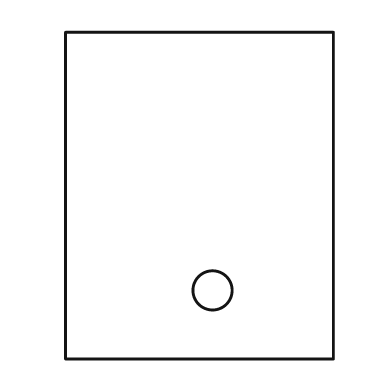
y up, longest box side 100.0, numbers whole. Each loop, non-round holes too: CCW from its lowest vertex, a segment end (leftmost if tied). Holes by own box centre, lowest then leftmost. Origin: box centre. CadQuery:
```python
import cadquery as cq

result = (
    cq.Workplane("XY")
    .moveTo(-41.0, -50.0)
    .lineTo(41.0, -50.0)
    .lineTo(41.0, 50.0)
    .lineTo(-41.0, 50.0)
    .close()
    .moveTo(4.0, -29.0)
    .circle(6.0)
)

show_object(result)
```